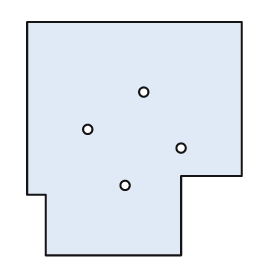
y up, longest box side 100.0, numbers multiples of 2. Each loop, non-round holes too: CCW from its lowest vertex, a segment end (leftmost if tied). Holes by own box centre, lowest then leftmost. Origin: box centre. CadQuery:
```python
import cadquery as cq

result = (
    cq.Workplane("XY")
    .moveTo(-38.0, -50.0)
    .lineTo(20.0, -50.0)
    .lineTo(20.0, -16.0)
    .lineTo(46.0, -16.0)
    .lineTo(46.0, 50.0)
    .lineTo(-46.0, 50.0)
    .lineTo(-46.0, -24.0)
    .lineTo(-38.0, -24.0)
    .close()
    .moveTo(-4.0, -20.0)
    .circle(2.0)
    .moveTo(20.0, -4.0)
    .circle(2.0)
    .moveTo(-20.0, 4.0)
    .circle(2.0)
    .moveTo(4.0, 20.0)
    .circle(2.0)
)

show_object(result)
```